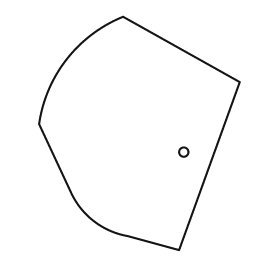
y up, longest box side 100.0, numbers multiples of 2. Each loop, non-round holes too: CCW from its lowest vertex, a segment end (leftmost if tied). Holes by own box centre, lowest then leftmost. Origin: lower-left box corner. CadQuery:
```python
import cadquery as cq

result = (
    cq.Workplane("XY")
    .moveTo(60.0, 0.0)
    .lineTo(86.0, 72.0)
    .lineTo(36.0, 100.0)
    .threePointArc((12.0, 82.0), (0.0, 54.0))
    .lineTo(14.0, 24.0)
    .threePointArc((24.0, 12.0), (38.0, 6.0))
    .close()
    .moveTo(62.0, 42.0)
    .circle(2.0)
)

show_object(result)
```